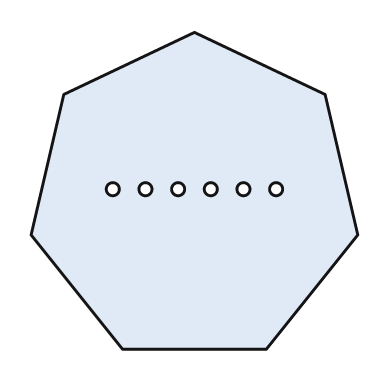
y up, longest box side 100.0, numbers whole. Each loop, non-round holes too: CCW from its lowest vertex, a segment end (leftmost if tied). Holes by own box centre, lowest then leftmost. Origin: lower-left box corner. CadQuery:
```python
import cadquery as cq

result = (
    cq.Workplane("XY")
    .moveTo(28.0, 0.0)
    .lineTo(72.0, 0.0)
    .lineTo(100.0, 35.0)
    .lineTo(90.0, 78.0)
    .lineTo(50.0, 97.0)
    .lineTo(10.0, 78.0)
    .lineTo(0.0, 35.0)
    .close()
    .moveTo(25.0, 49.0)
    .circle(2.0)
    .moveTo(35.0, 49.0)
    .circle(2.0)
    .moveTo(45.0, 49.0)
    .circle(2.0)
    .moveTo(55.0, 49.0)
    .circle(2.0)
    .moveTo(65.0, 49.0)
    .circle(2.0)
    .moveTo(75.0, 49.0)
    .circle(2.0)
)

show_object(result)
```